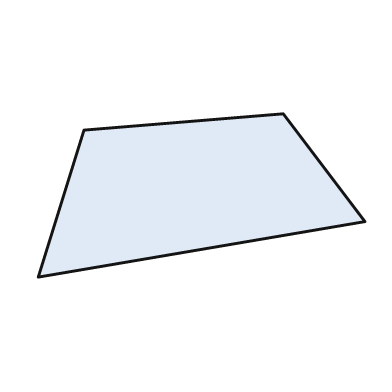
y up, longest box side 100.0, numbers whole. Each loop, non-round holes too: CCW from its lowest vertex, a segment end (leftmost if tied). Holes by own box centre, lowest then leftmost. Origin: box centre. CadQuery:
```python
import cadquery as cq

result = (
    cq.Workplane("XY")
    .moveTo(-50.0, -25.0)
    .lineTo(50.0, -8.0)
    .lineTo(25.0, 25.0)
    .lineTo(-36.0, 20.0)
    .close()
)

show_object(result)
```